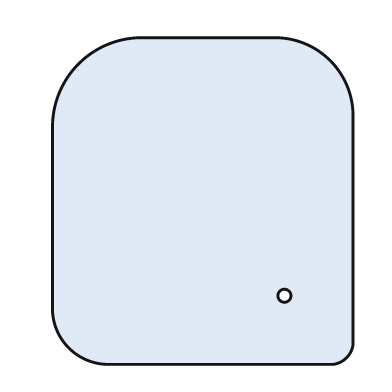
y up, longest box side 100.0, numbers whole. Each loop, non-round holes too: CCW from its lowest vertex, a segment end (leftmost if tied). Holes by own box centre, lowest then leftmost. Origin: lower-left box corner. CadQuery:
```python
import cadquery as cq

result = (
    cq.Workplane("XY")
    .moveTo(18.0, 0.0)
    .lineTo(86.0, 0.0)
    .threePointArc((90.0, 2.0), (92.0, 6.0))
    .lineTo(92.0, 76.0)
    .threePointArc((85.0, 93.0), (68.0, 100.0))
    .lineTo(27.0, 100.0)
    .threePointArc((8.0, 92.0), (0.0, 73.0))
    .lineTo(0.0, 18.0)
    .threePointArc((5.0, 5.0), (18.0, 0.0))
    .close()
    .moveTo(71.0, 21.0)
    .circle(2.0)
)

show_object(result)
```